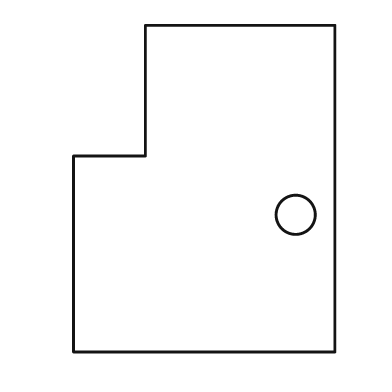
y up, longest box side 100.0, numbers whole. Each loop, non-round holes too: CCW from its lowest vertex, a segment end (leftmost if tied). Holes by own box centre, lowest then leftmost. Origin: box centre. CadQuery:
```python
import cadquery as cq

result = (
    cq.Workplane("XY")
    .moveTo(-40.0, -50.0)
    .lineTo(40.0, -50.0)
    .lineTo(40.0, 50.0)
    .lineTo(-18.0, 50.0)
    .lineTo(-18.0, 10.0)
    .lineTo(-40.0, 10.0)
    .close()
    .moveTo(28.0, -8.0)
    .circle(6.0)
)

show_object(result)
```